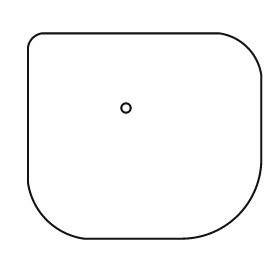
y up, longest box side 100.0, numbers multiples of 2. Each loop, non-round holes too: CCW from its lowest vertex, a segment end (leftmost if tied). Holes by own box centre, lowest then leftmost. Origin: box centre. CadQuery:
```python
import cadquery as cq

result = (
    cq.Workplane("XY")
    .moveTo(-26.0, -44.0)
    .lineTo(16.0, -44.0)
    .threePointArc((40.0, -34.0), (50.0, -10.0))
    .lineTo(50.0, 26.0)
    .threePointArc((44.0, 38.0), (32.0, 44.0))
    .lineTo(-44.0, 44.0)
    .threePointArc((-48.0, 42.0), (-50.0, 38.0))
    .lineTo(-50.0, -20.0)
    .threePointArc((-42.0, -36.0), (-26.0, -44.0))
    .close()
    .moveTo(-8.0, 12.0)
    .circle(2.0)
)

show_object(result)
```